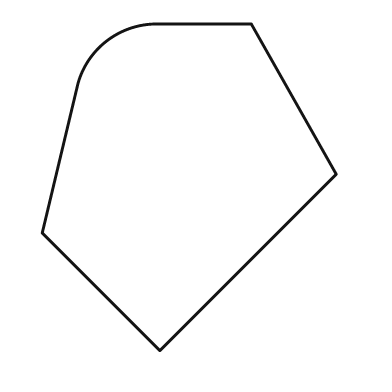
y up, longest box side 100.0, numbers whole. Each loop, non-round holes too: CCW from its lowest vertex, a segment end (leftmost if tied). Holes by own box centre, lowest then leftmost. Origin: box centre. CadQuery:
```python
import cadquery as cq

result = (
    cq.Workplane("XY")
    .moveTo(-9.0, -50.0)
    .lineTo(45.0, 4.0)
    .lineTo(19.0, 50.0)
    .lineTo(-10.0, 50.0)
    .threePointArc((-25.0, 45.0), (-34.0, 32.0))
    .lineTo(-45.0, -14.0)
    .close()
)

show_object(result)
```